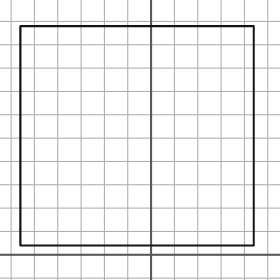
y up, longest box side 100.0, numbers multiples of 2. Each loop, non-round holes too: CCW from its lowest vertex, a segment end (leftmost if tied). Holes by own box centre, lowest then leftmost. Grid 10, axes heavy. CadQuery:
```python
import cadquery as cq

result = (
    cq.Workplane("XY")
    .moveTo(-56.0, 4.0)
    .lineTo(44.0, 4.0)
    .lineTo(44.0, 98.0)
    .lineTo(-56.0, 98.0)
    .close()
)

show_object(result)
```